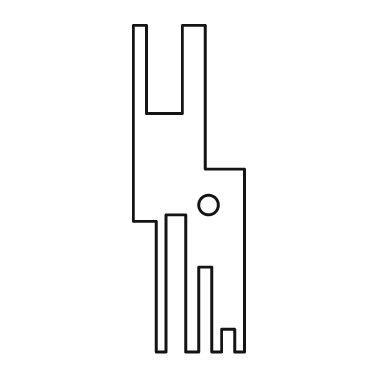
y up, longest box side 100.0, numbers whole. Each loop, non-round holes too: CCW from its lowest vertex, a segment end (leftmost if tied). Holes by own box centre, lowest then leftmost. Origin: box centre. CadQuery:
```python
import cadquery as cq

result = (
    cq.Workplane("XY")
    .moveTo(-10.0, -50.0)
    .lineTo(-7.0, -50.0)
    .lineTo(-7.0, -8.0)
    .lineTo(-1.0, -8.0)
    .lineTo(-1.0, -50.0)
    .lineTo(3.0, -50.0)
    .lineTo(3.0, -24.0)
    .lineTo(7.0, -24.0)
    .lineTo(7.0, -50.0)
    .lineTo(10.0, -50.0)
    .lineTo(10.0, -43.0)
    .lineTo(14.0, -43.0)
    .lineTo(14.0, -50.0)
    .lineTo(17.0, -50.0)
    .lineTo(17.0, 6.0)
    .lineTo(5.0, 6.0)
    .lineTo(5.0, 50.0)
    .lineTo(-2.0, 50.0)
    .lineTo(-2.0, 23.0)
    .lineTo(-13.0, 23.0)
    .lineTo(-13.0, 50.0)
    .lineTo(-17.0, 50.0)
    .lineTo(-17.0, -10.0)
    .lineTo(-10.0, -10.0)
    .close()
    .moveTo(6.0, -5.0)
    .circle(3.0)
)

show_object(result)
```